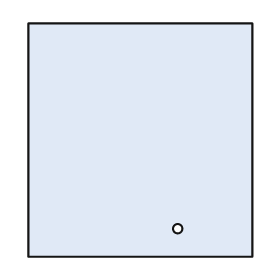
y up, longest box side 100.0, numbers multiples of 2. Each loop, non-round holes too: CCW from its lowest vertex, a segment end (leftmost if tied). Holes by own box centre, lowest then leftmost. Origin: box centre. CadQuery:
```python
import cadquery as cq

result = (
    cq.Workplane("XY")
    .moveTo(-48.0, -50.0)
    .lineTo(48.0, -50.0)
    .lineTo(48.0, 50.0)
    .lineTo(-48.0, 50.0)
    .close()
    .moveTo(16.0, -38.0)
    .circle(2.0)
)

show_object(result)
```